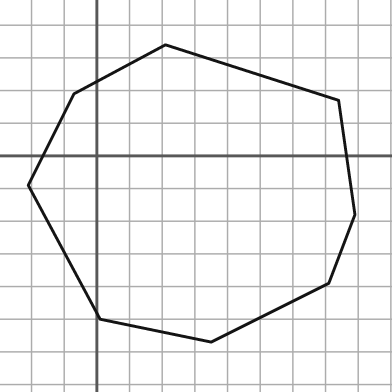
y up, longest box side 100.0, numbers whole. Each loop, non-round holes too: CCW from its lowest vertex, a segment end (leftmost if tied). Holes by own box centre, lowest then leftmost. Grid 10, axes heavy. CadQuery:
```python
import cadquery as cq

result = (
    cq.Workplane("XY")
    .moveTo(35.0, -57.0)
    .lineTo(71.0, -39.0)
    .lineTo(79.0, -18.0)
    .lineTo(74.0, 17.0)
    .lineTo(21.0, 34.0)
    .lineTo(-7.0, 19.0)
    .lineTo(-21.0, -9.0)
    .lineTo(1.0, -50.0)
    .close()
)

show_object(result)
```